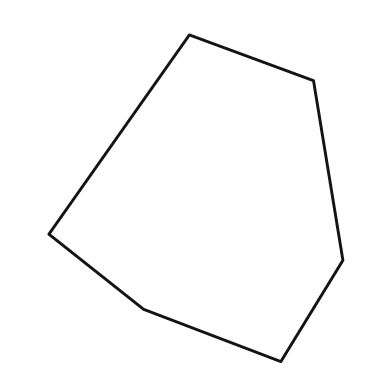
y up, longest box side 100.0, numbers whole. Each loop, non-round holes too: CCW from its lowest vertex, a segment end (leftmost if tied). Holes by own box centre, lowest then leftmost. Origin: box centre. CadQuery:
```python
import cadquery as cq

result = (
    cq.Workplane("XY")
    .moveTo(26.0, -50.0)
    .lineTo(45.0, -19.0)
    .lineTo(36.0, 36.0)
    .lineTo(-2.0, 50.0)
    .lineTo(-45.0, -11.0)
    .lineTo(-16.0, -34.0)
    .close()
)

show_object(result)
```